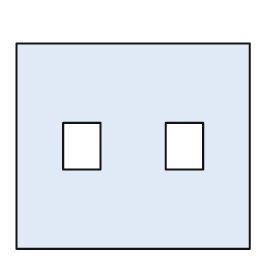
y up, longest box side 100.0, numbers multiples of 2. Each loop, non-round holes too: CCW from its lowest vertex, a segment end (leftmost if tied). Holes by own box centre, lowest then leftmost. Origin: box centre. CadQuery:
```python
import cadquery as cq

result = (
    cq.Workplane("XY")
    .moveTo(-50.0, -44.0)
    .lineTo(50.0, -44.0)
    .lineTo(50.0, 44.0)
    .lineTo(-50.0, 44.0)
    .close()
    .moveTo(-30.0, -10.0)
    .lineTo(-14.0, -10.0)
    .lineTo(-14.0, 10.0)
    .lineTo(-30.0, 10.0)
    .close()
    .moveTo(14.0, -10.0)
    .lineTo(30.0, -10.0)
    .lineTo(30.0, 10.0)
    .lineTo(14.0, 10.0)
    .close()
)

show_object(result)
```